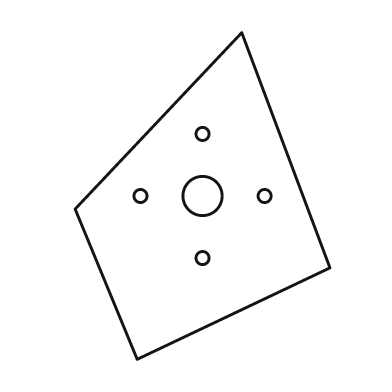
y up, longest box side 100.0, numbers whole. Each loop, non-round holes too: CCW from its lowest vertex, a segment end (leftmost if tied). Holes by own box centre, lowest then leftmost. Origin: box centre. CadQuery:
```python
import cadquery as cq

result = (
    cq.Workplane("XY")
    .moveTo(-20.0, -50.0)
    .lineTo(39.0, -22.0)
    .lineTo(12.0, 50.0)
    .lineTo(-39.0, -4.0)
    .close()
    .moveTo(0.0, -19.0)
    .circle(2.0)
    .moveTo(-19.0, 0.0)
    .circle(2.0)
    .moveTo(0.0, 0.0)
    .circle(6.0)
    .moveTo(19.0, 0.0)
    .circle(2.0)
    .moveTo(0.0, 19.0)
    .circle(2.0)
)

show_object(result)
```